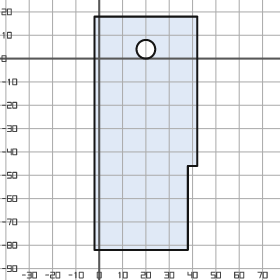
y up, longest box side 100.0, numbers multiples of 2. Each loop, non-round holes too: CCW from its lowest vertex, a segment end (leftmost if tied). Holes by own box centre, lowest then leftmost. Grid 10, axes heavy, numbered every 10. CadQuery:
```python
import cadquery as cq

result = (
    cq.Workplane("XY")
    .moveTo(-2.0, -82.0)
    .lineTo(38.0, -82.0)
    .lineTo(38.0, -46.0)
    .lineTo(42.0, -46.0)
    .lineTo(42.0, 18.0)
    .lineTo(-2.0, 18.0)
    .close()
    .moveTo(20.0, 4.0)
    .circle(4.0)
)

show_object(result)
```